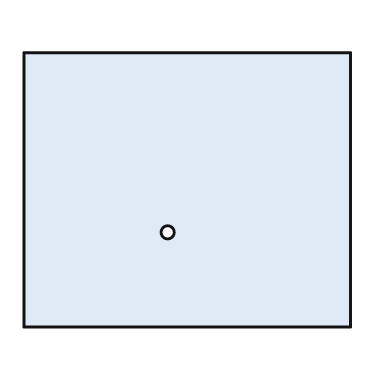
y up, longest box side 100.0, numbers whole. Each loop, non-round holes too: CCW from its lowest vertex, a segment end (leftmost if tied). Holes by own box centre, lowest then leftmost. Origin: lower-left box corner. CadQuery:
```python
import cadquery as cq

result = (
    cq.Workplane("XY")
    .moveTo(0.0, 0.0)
    .lineTo(100.0, 0.0)
    .lineTo(100.0, 84.0)
    .lineTo(0.0, 84.0)
    .close()
    .moveTo(44.0, 29.0)
    .circle(2.0)
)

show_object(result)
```